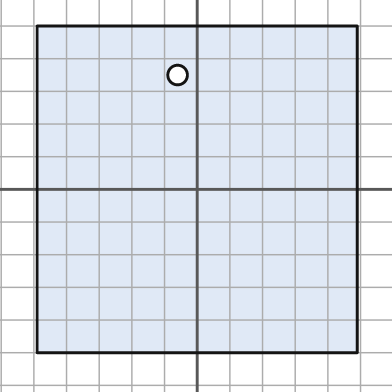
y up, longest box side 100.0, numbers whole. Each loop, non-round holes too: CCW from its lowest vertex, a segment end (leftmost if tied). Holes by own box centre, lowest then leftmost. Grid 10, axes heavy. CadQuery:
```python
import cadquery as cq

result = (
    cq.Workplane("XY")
    .moveTo(-49.0, -50.0)
    .lineTo(49.0, -50.0)
    .lineTo(49.0, 50.0)
    .lineTo(-49.0, 50.0)
    .close()
    .moveTo(-6.0, 35.0)
    .circle(3.0)
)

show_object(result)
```